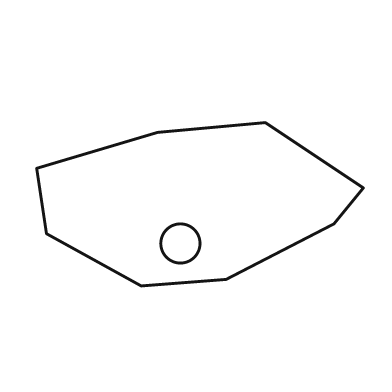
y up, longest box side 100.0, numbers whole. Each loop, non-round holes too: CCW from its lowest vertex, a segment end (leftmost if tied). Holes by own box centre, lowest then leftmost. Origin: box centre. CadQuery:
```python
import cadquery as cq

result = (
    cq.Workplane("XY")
    .moveTo(-18.0, -25.0)
    .lineTo(8.0, -23.0)
    .lineTo(41.0, -6.0)
    .lineTo(50.0, 5.0)
    .lineTo(20.0, 25.0)
    .lineTo(-13.0, 22.0)
    .lineTo(-50.0, 11.0)
    .lineTo(-47.0, -9.0)
    .close()
    .moveTo(-6.0, -12.0)
    .circle(6.0)
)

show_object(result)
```